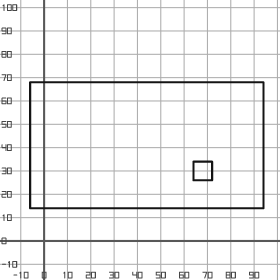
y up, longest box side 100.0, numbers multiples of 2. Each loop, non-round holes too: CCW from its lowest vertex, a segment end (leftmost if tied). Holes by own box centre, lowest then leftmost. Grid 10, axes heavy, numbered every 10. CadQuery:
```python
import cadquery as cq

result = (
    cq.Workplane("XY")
    .moveTo(-6.0, 14.0)
    .lineTo(94.0, 14.0)
    .lineTo(94.0, 68.0)
    .lineTo(-6.0, 68.0)
    .close()
    .moveTo(64.0, 26.0)
    .lineTo(72.0, 26.0)
    .lineTo(72.0, 34.0)
    .lineTo(64.0, 34.0)
    .close()
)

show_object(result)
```